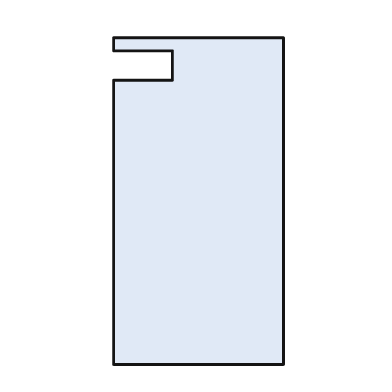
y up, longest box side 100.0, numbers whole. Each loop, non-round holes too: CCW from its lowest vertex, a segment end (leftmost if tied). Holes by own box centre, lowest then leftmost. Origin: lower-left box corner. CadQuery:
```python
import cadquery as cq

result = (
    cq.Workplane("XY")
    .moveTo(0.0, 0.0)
    .lineTo(52.0, 0.0)
    .lineTo(52.0, 100.0)
    .lineTo(0.0, 100.0)
    .lineTo(0.0, 96.0)
    .lineTo(18.0, 96.0)
    .lineTo(18.0, 87.0)
    .lineTo(0.0, 87.0)
    .close()
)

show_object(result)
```